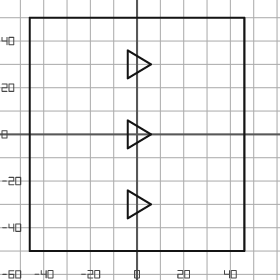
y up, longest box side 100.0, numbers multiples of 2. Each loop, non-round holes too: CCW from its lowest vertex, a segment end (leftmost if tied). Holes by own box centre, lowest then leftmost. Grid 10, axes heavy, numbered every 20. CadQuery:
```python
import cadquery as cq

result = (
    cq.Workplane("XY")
    .moveTo(-46.0, -50.0)
    .lineTo(46.0, -50.0)
    .lineTo(46.0, 50.0)
    .lineTo(-46.0, 50.0)
    .close()
    .moveTo(-4.0, -36.0)
    .lineTo(6.0, -30.0)
    .lineTo(-4.0, -24.0)
    .close()
    .moveTo(-4.0, -6.0)
    .lineTo(6.0, 0.0)
    .lineTo(-4.0, 6.0)
    .close()
    .moveTo(-4.0, 24.0)
    .lineTo(6.0, 30.0)
    .lineTo(-4.0, 36.0)
    .close()
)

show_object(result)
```